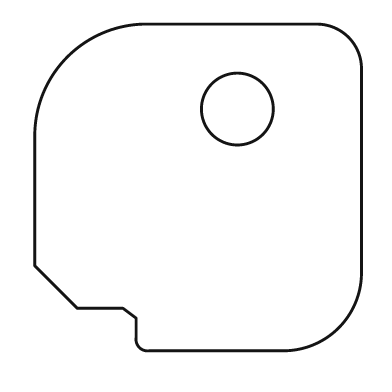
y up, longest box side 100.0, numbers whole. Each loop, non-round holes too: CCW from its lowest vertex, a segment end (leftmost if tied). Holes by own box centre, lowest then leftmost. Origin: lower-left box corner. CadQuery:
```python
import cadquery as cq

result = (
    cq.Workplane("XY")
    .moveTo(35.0, 0.0)
    .lineTo(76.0, 0.0)
    .threePointArc((93.0, 7.0), (100.0, 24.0))
    .lineTo(100.0, 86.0)
    .threePointArc((96.0, 96.0), (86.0, 100.0))
    .lineTo(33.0, 100.0)
    .threePointArc((10.0, 90.0), (0.0, 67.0))
    .lineTo(0.0, 26.0)
    .lineTo(13.0, 13.0)
    .lineTo(27.0, 13.0)
    .lineTo(31.0, 10.0)
    .lineTo(31.0, 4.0)
    .threePointArc((32.0, 1.0), (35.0, 0.0))
    .close()
    .moveTo(62.0, 74.0)
    .circle(11.0)
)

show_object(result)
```